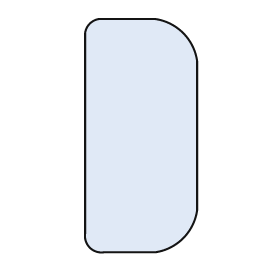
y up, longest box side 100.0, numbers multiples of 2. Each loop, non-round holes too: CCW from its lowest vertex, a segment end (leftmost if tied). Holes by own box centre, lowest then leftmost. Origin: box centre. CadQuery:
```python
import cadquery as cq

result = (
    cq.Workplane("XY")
    .moveTo(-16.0, -50.0)
    .lineTo(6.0, -50.0)
    .threePointArc((18.0, -44.0), (24.0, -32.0))
    .lineTo(24.0, 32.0)
    .threePointArc((18.0, 44.0), (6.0, 50.0))
    .lineTo(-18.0, 50.0)
    .threePointArc((-22.0, 48.0), (-24.0, 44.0))
    .lineTo(-24.0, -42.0)
    .threePointArc((-22.0, -48.0), (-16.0, -50.0))
    .close()
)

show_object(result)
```